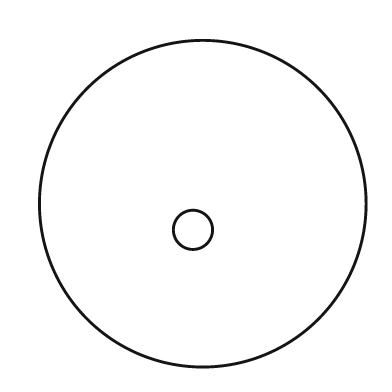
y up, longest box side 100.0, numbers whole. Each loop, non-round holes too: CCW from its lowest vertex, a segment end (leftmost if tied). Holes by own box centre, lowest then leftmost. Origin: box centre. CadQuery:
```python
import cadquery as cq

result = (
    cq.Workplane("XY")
    .moveTo(0.0, 0.0)
    .circle(50.0)
    .moveTo(-3.0, -8.0)
    .circle(6.0)
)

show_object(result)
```